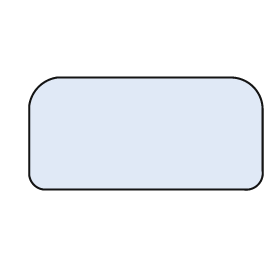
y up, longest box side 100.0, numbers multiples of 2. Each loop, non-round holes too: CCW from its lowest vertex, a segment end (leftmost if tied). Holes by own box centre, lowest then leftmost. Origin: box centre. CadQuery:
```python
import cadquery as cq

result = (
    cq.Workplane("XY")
    .moveTo(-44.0, -24.0)
    .lineTo(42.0, -24.0)
    .threePointArc((48.0, -22.0), (50.0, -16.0))
    .lineTo(50.0, 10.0)
    .threePointArc((46.0, 20.0), (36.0, 24.0))
    .lineTo(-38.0, 24.0)
    .threePointArc((-46.0, 20.0), (-50.0, 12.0))
    .lineTo(-50.0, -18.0)
    .threePointArc((-48.0, -22.0), (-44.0, -24.0))
    .close()
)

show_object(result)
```